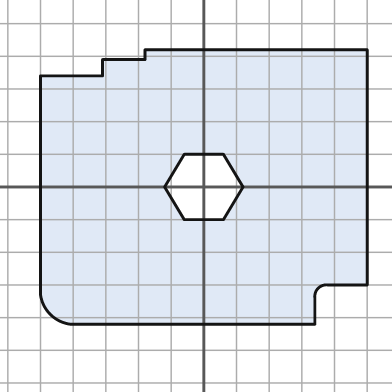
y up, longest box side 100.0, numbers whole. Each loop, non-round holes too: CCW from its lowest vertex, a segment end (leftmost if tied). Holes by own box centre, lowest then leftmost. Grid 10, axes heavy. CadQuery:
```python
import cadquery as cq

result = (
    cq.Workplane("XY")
    .moveTo(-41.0, -42.0)
    .lineTo(34.0, -42.0)
    .lineTo(34.0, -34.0)
    .threePointArc((35.0, -31.0), (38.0, -30.0))
    .lineTo(50.0, -30.0)
    .lineTo(50.0, 42.0)
    .lineTo(-18.0, 42.0)
    .lineTo(-18.0, 39.0)
    .lineTo(-31.0, 39.0)
    .lineTo(-31.0, 34.0)
    .lineTo(-50.0, 34.0)
    .lineTo(-50.0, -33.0)
    .threePointArc((-47.0, -39.0), (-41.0, -42.0))
    .close()
    .moveTo(-6.0, -10.0)
    .lineTo(6.0, -10.0)
    .lineTo(12.0, 0.0)
    .lineTo(6.0, 10.0)
    .lineTo(-6.0, 10.0)
    .lineTo(-12.0, 0.0)
    .close()
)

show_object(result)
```